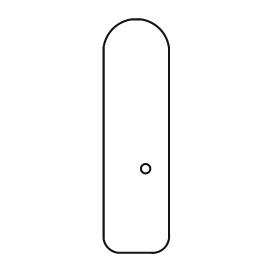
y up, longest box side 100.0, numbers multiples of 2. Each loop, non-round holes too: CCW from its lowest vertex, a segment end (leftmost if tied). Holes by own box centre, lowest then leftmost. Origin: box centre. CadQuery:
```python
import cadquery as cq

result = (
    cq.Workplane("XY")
    .moveTo(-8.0, -50.0)
    .lineTo(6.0, -50.0)
    .threePointArc((12.0, -48.0), (14.0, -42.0))
    .lineTo(14.0, 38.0)
    .threePointArc((10.0, 46.0), (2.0, 50.0))
    .lineTo(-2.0, 50.0)
    .threePointArc((-10.0, 46.0), (-14.0, 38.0))
    .lineTo(-14.0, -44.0)
    .threePointArc((-12.0, -48.0), (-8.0, -50.0))
    .close()
    .moveTo(4.0, -14.0)
    .circle(2.0)
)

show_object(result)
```